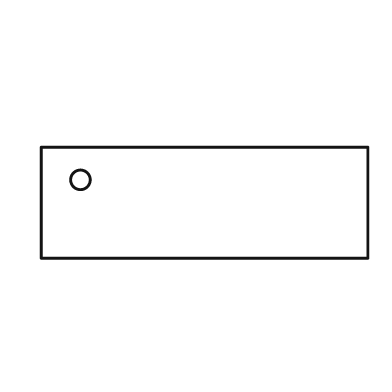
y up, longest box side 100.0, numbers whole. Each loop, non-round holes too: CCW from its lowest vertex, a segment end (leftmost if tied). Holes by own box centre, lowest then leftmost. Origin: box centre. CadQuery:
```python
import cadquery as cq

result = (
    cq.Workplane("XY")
    .moveTo(-50.0, -17.0)
    .lineTo(50.0, -17.0)
    .lineTo(50.0, 17.0)
    .lineTo(-50.0, 17.0)
    .close()
    .moveTo(-38.0, 7.0)
    .circle(3.0)
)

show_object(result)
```